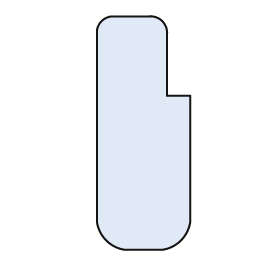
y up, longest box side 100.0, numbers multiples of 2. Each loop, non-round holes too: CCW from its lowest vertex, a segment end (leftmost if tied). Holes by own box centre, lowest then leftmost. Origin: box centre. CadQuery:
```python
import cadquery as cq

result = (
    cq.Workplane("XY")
    .moveTo(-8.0, -50.0)
    .lineTo(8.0, -50.0)
    .threePointArc((16.0, -46.0), (20.0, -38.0))
    .lineTo(20.0, 16.0)
    .lineTo(10.0, 16.0)
    .lineTo(10.0, 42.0)
    .threePointArc((8.0, 48.0), (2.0, 50.0))
    .lineTo(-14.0, 50.0)
    .threePointArc((-18.0, 48.0), (-20.0, 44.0))
    .lineTo(-20.0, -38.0)
    .threePointArc((-16.0, -46.0), (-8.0, -50.0))
    .close()
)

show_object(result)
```